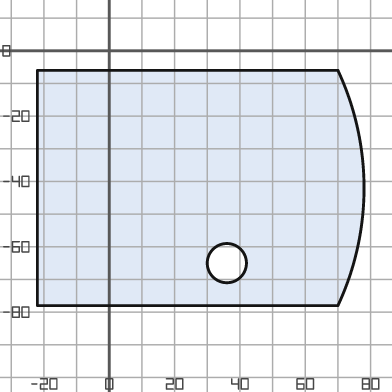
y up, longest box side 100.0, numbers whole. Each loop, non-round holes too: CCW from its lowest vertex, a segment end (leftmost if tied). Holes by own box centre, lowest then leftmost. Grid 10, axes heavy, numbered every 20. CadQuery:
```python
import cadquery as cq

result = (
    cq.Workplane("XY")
    .moveTo(-22.0, -78.0)
    .lineTo(70.0, -78.0)
    .threePointArc((78.0, -42.0), (70.0, -6.0))
    .lineTo(-22.0, -6.0)
    .close()
    .moveTo(36.0, -65.0)
    .circle(6.0)
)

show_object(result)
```